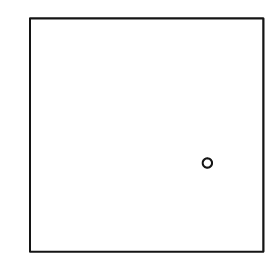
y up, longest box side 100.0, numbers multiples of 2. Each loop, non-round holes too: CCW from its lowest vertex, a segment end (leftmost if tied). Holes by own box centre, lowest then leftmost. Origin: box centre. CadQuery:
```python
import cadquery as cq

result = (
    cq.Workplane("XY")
    .moveTo(-50.0, -50.0)
    .lineTo(50.0, -50.0)
    .lineTo(50.0, 50.0)
    .lineTo(-50.0, 50.0)
    .close()
    .moveTo(26.0, -12.0)
    .circle(2.0)
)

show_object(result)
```